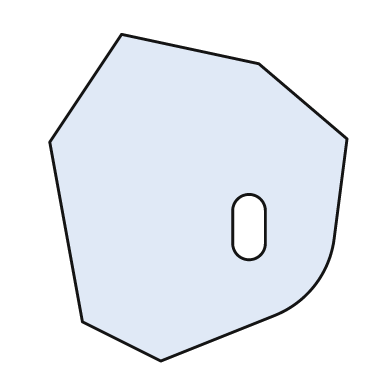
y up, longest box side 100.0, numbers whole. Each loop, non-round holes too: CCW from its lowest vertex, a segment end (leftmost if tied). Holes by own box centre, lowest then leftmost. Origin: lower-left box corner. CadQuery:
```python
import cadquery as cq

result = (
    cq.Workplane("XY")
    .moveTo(34.0, 0.0)
    .lineTo(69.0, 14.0)
    .threePointArc((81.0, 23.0), (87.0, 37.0))
    .lineTo(91.0, 68.0)
    .lineTo(64.0, 91.0)
    .lineTo(22.0, 100.0)
    .lineTo(0.0, 67.0)
    .lineTo(10.0, 12.0)
    .close()
    .moveTo(56.0, 36.0)
    .threePointArc((61.0, 31.0), (66.0, 36.0))
    .lineTo(66.0, 46.0)
    .threePointArc((61.0, 51.0), (56.0, 46.0))
    .close()
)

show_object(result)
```